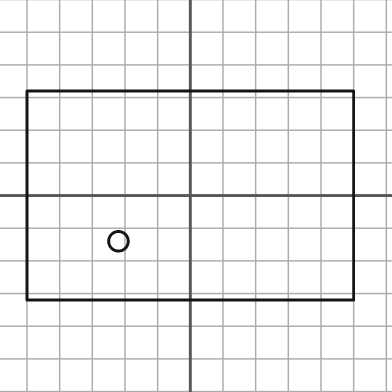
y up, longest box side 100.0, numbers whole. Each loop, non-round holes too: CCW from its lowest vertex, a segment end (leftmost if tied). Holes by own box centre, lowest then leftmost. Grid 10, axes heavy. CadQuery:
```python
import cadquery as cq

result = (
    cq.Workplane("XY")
    .moveTo(-50.0, -32.0)
    .lineTo(50.0, -32.0)
    .lineTo(50.0, 32.0)
    .lineTo(-50.0, 32.0)
    .close()
    .moveTo(-22.0, -14.0)
    .circle(3.0)
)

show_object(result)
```